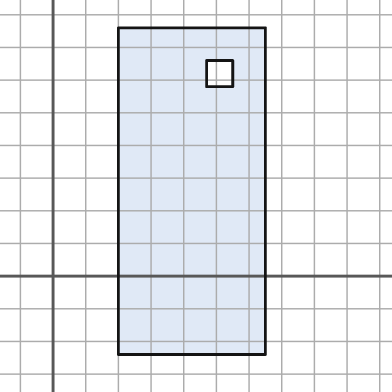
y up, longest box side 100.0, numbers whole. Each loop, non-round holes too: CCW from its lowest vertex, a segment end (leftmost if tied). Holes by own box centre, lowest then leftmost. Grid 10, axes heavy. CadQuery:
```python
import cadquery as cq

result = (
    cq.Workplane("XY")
    .moveTo(20.0, -24.0)
    .lineTo(65.0, -24.0)
    .lineTo(65.0, 76.0)
    .lineTo(20.0, 76.0)
    .close()
    .moveTo(47.0, 58.0)
    .lineTo(55.0, 58.0)
    .lineTo(55.0, 66.0)
    .lineTo(47.0, 66.0)
    .close()
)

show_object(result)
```